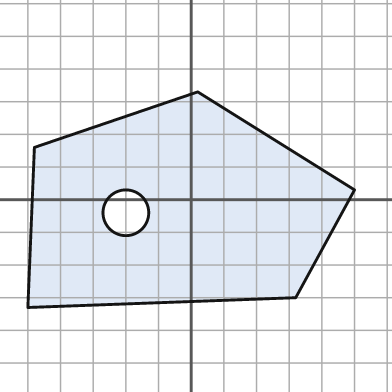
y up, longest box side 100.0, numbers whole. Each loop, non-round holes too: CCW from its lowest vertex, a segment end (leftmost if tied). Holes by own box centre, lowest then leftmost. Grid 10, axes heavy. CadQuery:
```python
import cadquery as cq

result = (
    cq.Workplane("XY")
    .moveTo(-50.0, -33.0)
    .lineTo(32.0, -30.0)
    .lineTo(50.0, 3.0)
    .lineTo(2.0, 33.0)
    .lineTo(-48.0, 16.0)
    .close()
    .moveTo(-20.0, -4.0)
    .circle(7.0)
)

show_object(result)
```